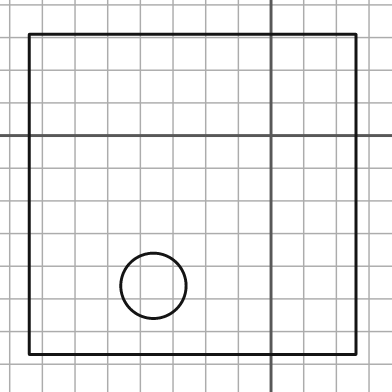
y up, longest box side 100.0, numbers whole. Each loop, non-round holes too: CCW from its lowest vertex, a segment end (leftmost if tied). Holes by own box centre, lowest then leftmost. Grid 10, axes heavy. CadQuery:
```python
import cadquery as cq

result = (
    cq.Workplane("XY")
    .moveTo(-74.0, -67.0)
    .lineTo(26.0, -67.0)
    .lineTo(26.0, 31.0)
    .lineTo(-74.0, 31.0)
    .close()
    .moveTo(-36.0, -46.0)
    .circle(10.0)
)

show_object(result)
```